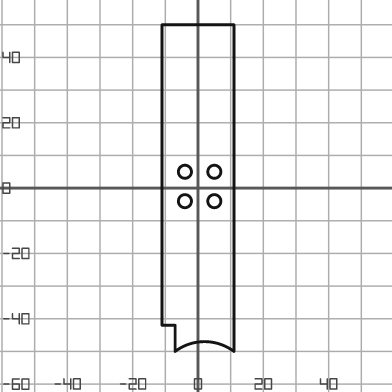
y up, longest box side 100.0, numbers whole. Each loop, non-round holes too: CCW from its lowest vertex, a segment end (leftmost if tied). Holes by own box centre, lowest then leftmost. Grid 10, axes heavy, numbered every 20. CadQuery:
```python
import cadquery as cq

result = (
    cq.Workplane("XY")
    .moveTo(-7.0, -50.0)
    .threePointArc((2.0, -47.0), (11.0, -50.0))
    .lineTo(11.0, 50.0)
    .lineTo(-11.0, 50.0)
    .lineTo(-11.0, -42.0)
    .lineTo(-7.0, -42.0)
    .close()
    .moveTo(-4.0, -4.0)
    .circle(2.0)
    .moveTo(5.0, -4.0)
    .circle(2.0)
    .moveTo(-4.0, 5.0)
    .circle(2.0)
    .moveTo(5.0, 5.0)
    .circle(2.0)
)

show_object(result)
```